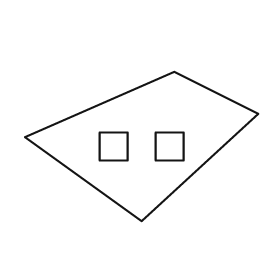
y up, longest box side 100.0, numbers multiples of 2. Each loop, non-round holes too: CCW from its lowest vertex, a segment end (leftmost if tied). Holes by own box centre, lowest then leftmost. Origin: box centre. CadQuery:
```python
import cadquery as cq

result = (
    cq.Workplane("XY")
    .moveTo(0.0, -32.0)
    .lineTo(50.0, 14.0)
    .lineTo(14.0, 32.0)
    .lineTo(-50.0, 4.0)
    .close()
    .moveTo(-18.0, -6.0)
    .lineTo(-6.0, -6.0)
    .lineTo(-6.0, 6.0)
    .lineTo(-18.0, 6.0)
    .close()
    .moveTo(6.0, -6.0)
    .lineTo(18.0, -6.0)
    .lineTo(18.0, 6.0)
    .lineTo(6.0, 6.0)
    .close()
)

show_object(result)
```